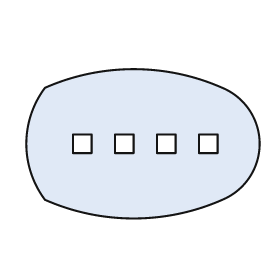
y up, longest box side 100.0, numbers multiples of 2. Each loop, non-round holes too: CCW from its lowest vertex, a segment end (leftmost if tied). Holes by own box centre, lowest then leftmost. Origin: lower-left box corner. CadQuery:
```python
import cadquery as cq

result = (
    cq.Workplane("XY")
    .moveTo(8.0, 8.0)
    .threePointArc((46.0, 0.0), (84.0, 8.0))
    .threePointArc((100.0, 32.0), (84.0, 56.0))
    .threePointArc((46.0, 64.0), (8.0, 56.0))
    .threePointArc((0.0, 32.0), (8.0, 8.0))
    .close()
    .moveTo(20.0, 28.0)
    .lineTo(28.0, 28.0)
    .lineTo(28.0, 36.0)
    .lineTo(20.0, 36.0)
    .close()
    .moveTo(38.0, 28.0)
    .lineTo(46.0, 28.0)
    .lineTo(46.0, 36.0)
    .lineTo(38.0, 36.0)
    .close()
    .moveTo(56.0, 28.0)
    .lineTo(64.0, 28.0)
    .lineTo(64.0, 36.0)
    .lineTo(56.0, 36.0)
    .close()
    .moveTo(74.0, 28.0)
    .lineTo(82.0, 28.0)
    .lineTo(82.0, 36.0)
    .lineTo(74.0, 36.0)
    .close()
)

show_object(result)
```